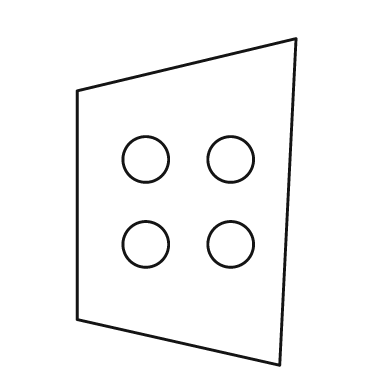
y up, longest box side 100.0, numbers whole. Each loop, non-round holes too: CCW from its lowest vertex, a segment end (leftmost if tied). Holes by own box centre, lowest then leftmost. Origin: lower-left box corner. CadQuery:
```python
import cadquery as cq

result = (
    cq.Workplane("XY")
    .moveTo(62.0, 0.0)
    .lineTo(67.0, 100.0)
    .lineTo(0.0, 84.0)
    .lineTo(0.0, 14.0)
    .close()
    .moveTo(21.0, 37.0)
    .circle(7.0)
    .moveTo(47.0, 37.0)
    .circle(7.0)
    .moveTo(21.0, 63.0)
    .circle(7.0)
    .moveTo(47.0, 63.0)
    .circle(7.0)
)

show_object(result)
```